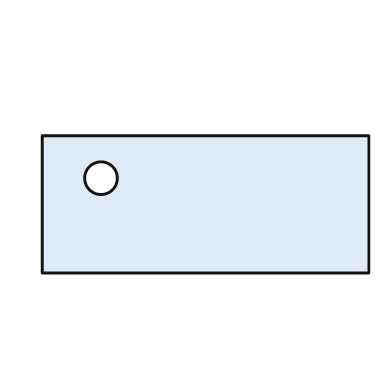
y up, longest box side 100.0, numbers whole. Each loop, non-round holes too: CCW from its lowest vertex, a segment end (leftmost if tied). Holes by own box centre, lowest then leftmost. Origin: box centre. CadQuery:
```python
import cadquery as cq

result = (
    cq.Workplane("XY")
    .moveTo(-50.0, -21.0)
    .lineTo(50.0, -21.0)
    .lineTo(50.0, 21.0)
    .lineTo(-50.0, 21.0)
    .close()
    .moveTo(-32.0, 8.0)
    .circle(5.0)
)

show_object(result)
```